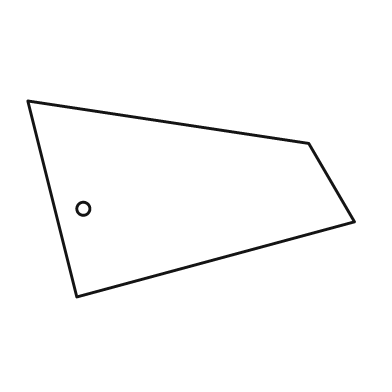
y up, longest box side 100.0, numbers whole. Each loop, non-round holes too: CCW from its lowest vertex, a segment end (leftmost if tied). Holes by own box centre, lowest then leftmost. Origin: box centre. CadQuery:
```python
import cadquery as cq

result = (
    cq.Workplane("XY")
    .moveTo(-35.0, -30.0)
    .lineTo(50.0, -7.0)
    .lineTo(36.0, 17.0)
    .lineTo(-50.0, 30.0)
    .close()
    .moveTo(-33.0, -3.0)
    .circle(2.0)
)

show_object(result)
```